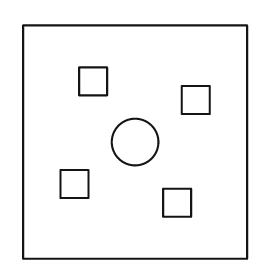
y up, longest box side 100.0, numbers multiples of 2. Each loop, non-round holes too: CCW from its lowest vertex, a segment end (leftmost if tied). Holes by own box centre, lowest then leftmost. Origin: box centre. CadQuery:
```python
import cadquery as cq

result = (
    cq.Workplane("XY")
    .moveTo(-48.0, -50.0)
    .lineTo(48.0, -50.0)
    .lineTo(48.0, 50.0)
    .lineTo(-48.0, 50.0)
    .close()
    .moveTo(12.0, -32.0)
    .lineTo(24.0, -32.0)
    .lineTo(24.0, -20.0)
    .lineTo(12.0, -20.0)
    .close()
    .moveTo(-32.0, -24.0)
    .lineTo(-20.0, -24.0)
    .lineTo(-20.0, -12.0)
    .lineTo(-32.0, -12.0)
    .close()
    .moveTo(0.0, 0.0)
    .circle(10.0)
    .moveTo(20.0, 12.0)
    .lineTo(32.0, 12.0)
    .lineTo(32.0, 24.0)
    .lineTo(20.0, 24.0)
    .close()
    .moveTo(-24.0, 20.0)
    .lineTo(-12.0, 20.0)
    .lineTo(-12.0, 32.0)
    .lineTo(-24.0, 32.0)
    .close()
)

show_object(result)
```